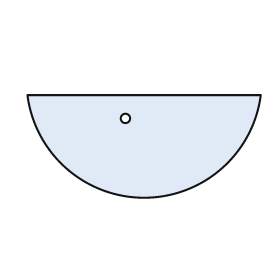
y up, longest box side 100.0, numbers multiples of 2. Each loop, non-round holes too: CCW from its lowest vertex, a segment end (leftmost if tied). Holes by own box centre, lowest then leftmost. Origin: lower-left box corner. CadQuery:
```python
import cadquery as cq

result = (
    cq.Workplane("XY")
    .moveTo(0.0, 44.0)
    .threePointArc((50.0, 0.0), (100.0, 44.0))
    .close()
    .moveTo(42.0, 34.0)
    .circle(2.0)
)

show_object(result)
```